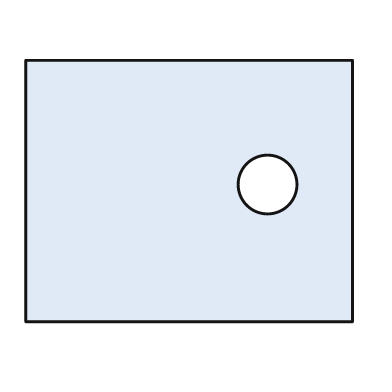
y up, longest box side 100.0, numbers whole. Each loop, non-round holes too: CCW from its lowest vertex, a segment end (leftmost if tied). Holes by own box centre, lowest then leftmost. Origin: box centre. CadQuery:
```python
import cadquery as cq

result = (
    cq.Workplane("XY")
    .moveTo(-50.0, -40.0)
    .lineTo(50.0, -40.0)
    .lineTo(50.0, 40.0)
    .lineTo(-50.0, 40.0)
    .close()
    .moveTo(24.0, 2.0)
    .circle(9.0)
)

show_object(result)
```